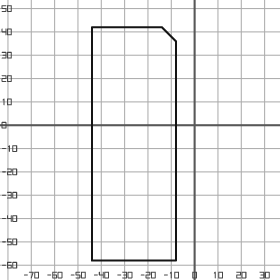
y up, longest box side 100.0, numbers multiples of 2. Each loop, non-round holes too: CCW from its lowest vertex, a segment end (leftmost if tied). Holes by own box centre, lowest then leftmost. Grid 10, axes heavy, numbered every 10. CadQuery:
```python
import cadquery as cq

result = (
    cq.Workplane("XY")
    .moveTo(-44.0, -58.0)
    .lineTo(-8.0, -58.0)
    .lineTo(-8.0, 36.0)
    .lineTo(-14.0, 42.0)
    .lineTo(-44.0, 42.0)
    .close()
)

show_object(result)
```